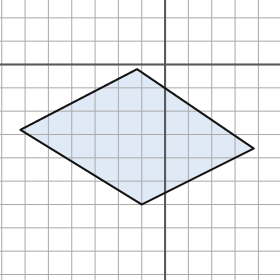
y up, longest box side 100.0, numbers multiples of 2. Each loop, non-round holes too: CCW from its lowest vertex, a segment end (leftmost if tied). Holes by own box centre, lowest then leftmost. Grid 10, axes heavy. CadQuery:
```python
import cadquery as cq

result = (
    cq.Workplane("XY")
    .moveTo(-10.0, -60.0)
    .lineTo(38.0, -36.0)
    .lineTo(-12.0, -2.0)
    .lineTo(-62.0, -28.0)
    .close()
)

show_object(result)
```